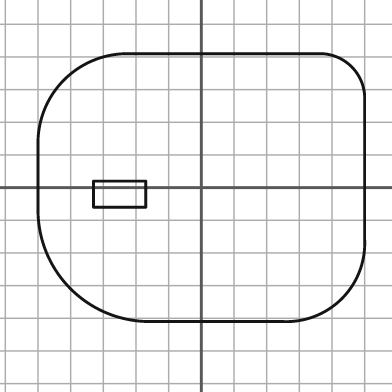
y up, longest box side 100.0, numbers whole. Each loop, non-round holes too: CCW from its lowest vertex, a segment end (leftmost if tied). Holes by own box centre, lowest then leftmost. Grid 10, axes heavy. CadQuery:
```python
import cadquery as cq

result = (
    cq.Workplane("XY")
    .moveTo(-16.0, -41.0)
    .lineTo(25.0, -41.0)
    .threePointArc((43.0, -34.0), (50.0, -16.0))
    .lineTo(50.0, 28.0)
    .threePointArc((46.0, 37.0), (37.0, 41.0))
    .lineTo(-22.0, 41.0)
    .threePointArc((-42.0, 33.0), (-50.0, 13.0))
    .lineTo(-50.0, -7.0)
    .threePointArc((-40.0, -31.0), (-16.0, -41.0))
    .close()
    .moveTo(-33.0, -6.0)
    .lineTo(-17.0, -6.0)
    .lineTo(-17.0, 2.0)
    .lineTo(-33.0, 2.0)
    .close()
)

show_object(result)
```